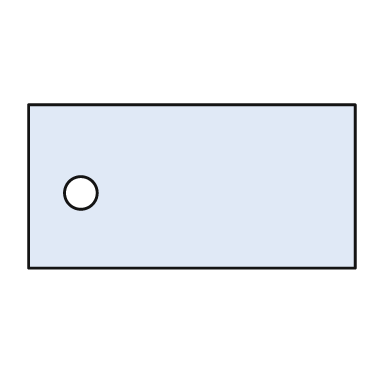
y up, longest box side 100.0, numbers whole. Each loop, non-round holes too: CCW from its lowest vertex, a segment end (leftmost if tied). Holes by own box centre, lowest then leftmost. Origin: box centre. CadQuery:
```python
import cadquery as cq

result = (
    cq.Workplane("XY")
    .moveTo(-50.0, -25.0)
    .lineTo(50.0, -25.0)
    .lineTo(50.0, 25.0)
    .lineTo(-50.0, 25.0)
    .close()
    .moveTo(-34.0, -2.0)
    .circle(5.0)
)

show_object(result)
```